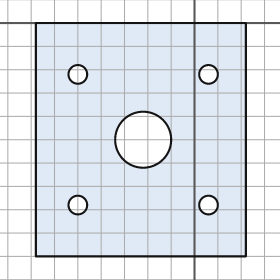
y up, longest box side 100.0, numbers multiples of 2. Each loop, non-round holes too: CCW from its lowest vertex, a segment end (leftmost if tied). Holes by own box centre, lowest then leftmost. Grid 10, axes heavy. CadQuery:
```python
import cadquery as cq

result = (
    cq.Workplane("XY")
    .moveTo(-68.0, -100.0)
    .lineTo(22.0, -100.0)
    .lineTo(22.0, 0.0)
    .lineTo(-68.0, 0.0)
    .close()
    .moveTo(-50.0, -78.0)
    .circle(4.0)
    .moveTo(6.0, -78.0)
    .circle(4.0)
    .moveTo(-22.0, -50.0)
    .circle(12.0)
    .moveTo(-50.0, -22.0)
    .circle(4.0)
    .moveTo(6.0, -22.0)
    .circle(4.0)
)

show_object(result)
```